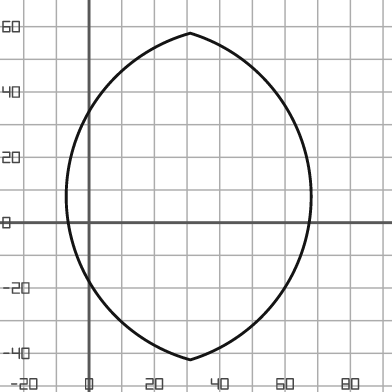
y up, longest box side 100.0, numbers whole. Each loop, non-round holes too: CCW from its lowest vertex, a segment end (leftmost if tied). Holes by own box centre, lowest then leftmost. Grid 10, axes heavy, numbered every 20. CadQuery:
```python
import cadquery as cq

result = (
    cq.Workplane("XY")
    .moveTo(31.0, -42.0)
    .threePointArc((68.0, 8.0), (31.0, 58.0))
    .threePointArc((-7.0, 8.0), (31.0, -42.0))
    .close()
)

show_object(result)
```